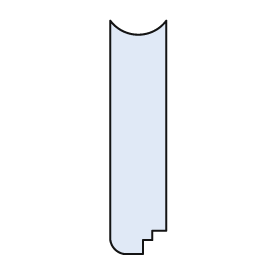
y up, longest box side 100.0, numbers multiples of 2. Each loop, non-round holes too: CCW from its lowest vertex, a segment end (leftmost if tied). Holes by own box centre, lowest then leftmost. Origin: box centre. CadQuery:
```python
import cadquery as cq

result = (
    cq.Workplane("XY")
    .moveTo(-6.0, -50.0)
    .lineTo(2.0, -50.0)
    .lineTo(2.0, -44.0)
    .lineTo(6.0, -44.0)
    .lineTo(6.0, -40.0)
    .lineTo(12.0, -40.0)
    .lineTo(12.0, 50.0)
    .threePointArc((0.0, 44.0), (-12.0, 50.0))
    .lineTo(-12.0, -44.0)
    .threePointArc((-10.0, -48.0), (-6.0, -50.0))
    .close()
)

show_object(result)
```